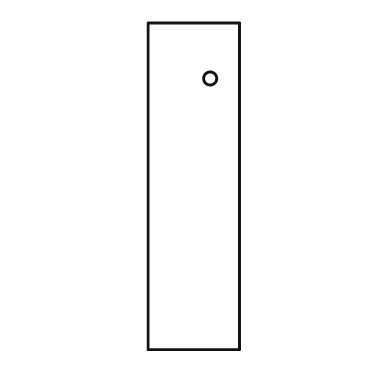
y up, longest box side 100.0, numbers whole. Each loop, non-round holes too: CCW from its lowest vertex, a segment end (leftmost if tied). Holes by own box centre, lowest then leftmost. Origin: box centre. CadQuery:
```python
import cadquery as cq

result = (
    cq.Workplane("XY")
    .moveTo(-14.0, -50.0)
    .lineTo(14.0, -50.0)
    .lineTo(14.0, 50.0)
    .lineTo(-14.0, 50.0)
    .close()
    .moveTo(5.0, 33.0)
    .circle(2.0)
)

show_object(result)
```